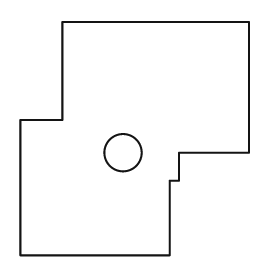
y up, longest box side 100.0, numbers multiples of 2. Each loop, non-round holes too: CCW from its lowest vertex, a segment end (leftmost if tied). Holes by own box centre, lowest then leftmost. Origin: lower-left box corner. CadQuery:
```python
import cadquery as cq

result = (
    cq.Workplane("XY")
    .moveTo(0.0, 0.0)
    .lineTo(64.0, 0.0)
    .lineTo(64.0, 32.0)
    .lineTo(68.0, 32.0)
    .lineTo(68.0, 44.0)
    .lineTo(98.0, 44.0)
    .lineTo(98.0, 100.0)
    .lineTo(18.0, 100.0)
    .lineTo(18.0, 58.0)
    .lineTo(0.0, 58.0)
    .close()
    .moveTo(44.0, 44.0)
    .circle(8.0)
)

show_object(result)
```